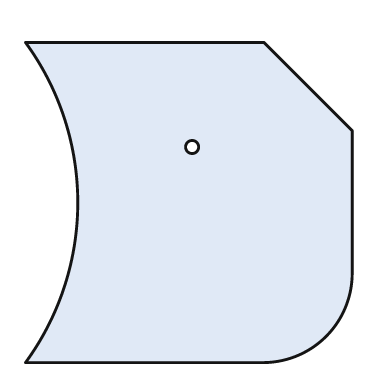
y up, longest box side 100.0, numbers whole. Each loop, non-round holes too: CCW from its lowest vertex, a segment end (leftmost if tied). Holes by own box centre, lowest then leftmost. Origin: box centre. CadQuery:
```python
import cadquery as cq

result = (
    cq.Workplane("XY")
    .moveTo(-50.0, -49.0)
    .lineTo(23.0, -49.0)
    .threePointArc((42.0, -41.0), (50.0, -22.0))
    .lineTo(50.0, 22.0)
    .lineTo(23.0, 49.0)
    .lineTo(-50.0, 49.0)
    .threePointArc((-34.0, 0.0), (-50.0, -49.0))
    .close()
    .moveTo(1.0, 17.0)
    .circle(2.0)
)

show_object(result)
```